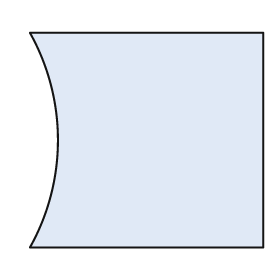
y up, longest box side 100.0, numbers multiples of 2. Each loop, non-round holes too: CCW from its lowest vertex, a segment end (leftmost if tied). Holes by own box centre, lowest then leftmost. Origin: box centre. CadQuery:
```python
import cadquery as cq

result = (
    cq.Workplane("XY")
    .moveTo(-50.0, -46.0)
    .lineTo(50.0, -46.0)
    .lineTo(50.0, 46.0)
    .lineTo(-50.0, 46.0)
    .threePointArc((-38.0, 0.0), (-50.0, -46.0))
    .close()
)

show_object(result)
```